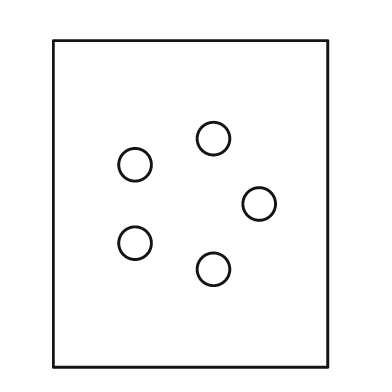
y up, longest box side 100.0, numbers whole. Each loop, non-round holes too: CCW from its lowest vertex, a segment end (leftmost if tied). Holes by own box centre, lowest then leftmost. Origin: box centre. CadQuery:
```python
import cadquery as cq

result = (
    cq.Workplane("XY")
    .moveTo(-42.0, -50.0)
    .lineTo(42.0, -50.0)
    .lineTo(42.0, 50.0)
    .lineTo(-42.0, 50.0)
    .close()
    .moveTo(7.0, -20.0)
    .circle(5.0)
    .moveTo(-17.0, -12.0)
    .circle(5.0)
    .moveTo(21.0, 0.0)
    .circle(5.0)
    .moveTo(-17.0, 12.0)
    .circle(5.0)
    .moveTo(7.0, 20.0)
    .circle(5.0)
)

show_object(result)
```